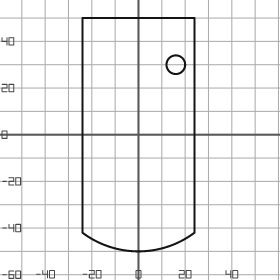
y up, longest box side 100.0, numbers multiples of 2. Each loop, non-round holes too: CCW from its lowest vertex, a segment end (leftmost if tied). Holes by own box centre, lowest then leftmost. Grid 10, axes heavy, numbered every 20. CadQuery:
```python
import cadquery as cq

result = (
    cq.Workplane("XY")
    .moveTo(-24.0, -42.0)
    .threePointArc((0.0, -50.0), (24.0, -42.0))
    .lineTo(24.0, 50.0)
    .lineTo(-24.0, 50.0)
    .close()
    .moveTo(16.0, 30.0)
    .circle(4.0)
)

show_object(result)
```